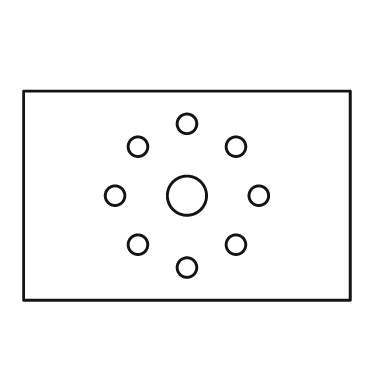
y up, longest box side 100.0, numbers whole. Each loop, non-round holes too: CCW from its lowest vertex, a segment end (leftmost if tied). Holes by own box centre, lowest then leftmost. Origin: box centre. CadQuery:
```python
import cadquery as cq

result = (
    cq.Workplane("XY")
    .moveTo(-50.0, -32.0)
    .lineTo(50.0, -32.0)
    .lineTo(50.0, 32.0)
    .lineTo(-50.0, 32.0)
    .close()
    .moveTo(0.0, -22.0)
    .circle(3.0)
    .moveTo(-15.0, -15.0)
    .circle(3.0)
    .moveTo(15.0, -15.0)
    .circle(3.0)
    .moveTo(-22.0, 0.0)
    .circle(3.0)
    .moveTo(0.0, 0.0)
    .circle(6.0)
    .moveTo(22.0, 0.0)
    .circle(3.0)
    .moveTo(-15.0, 15.0)
    .circle(3.0)
    .moveTo(15.0, 15.0)
    .circle(3.0)
    .moveTo(0.0, 22.0)
    .circle(3.0)
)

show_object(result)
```